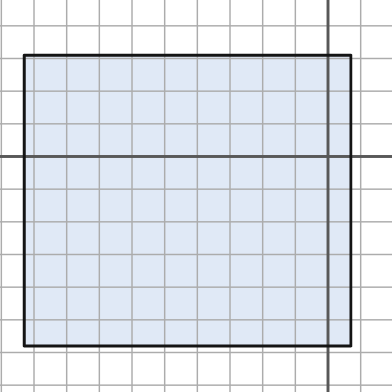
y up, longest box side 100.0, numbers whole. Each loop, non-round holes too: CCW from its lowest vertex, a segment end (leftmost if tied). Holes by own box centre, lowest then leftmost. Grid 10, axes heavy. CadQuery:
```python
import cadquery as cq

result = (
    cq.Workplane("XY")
    .moveTo(-93.0, -58.0)
    .lineTo(7.0, -58.0)
    .lineTo(7.0, 31.0)
    .lineTo(-93.0, 31.0)
    .close()
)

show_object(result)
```